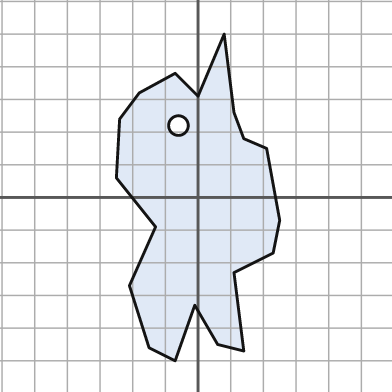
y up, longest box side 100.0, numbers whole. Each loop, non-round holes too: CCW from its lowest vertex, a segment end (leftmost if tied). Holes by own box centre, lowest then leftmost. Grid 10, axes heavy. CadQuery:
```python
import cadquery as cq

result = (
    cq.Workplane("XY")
    .moveTo(-7.0, -50.0)
    .lineTo(-1.0, -33.0)
    .lineTo(6.0, -45.0)
    .lineTo(14.0, -47.0)
    .lineTo(11.0, -23.0)
    .lineTo(23.0, -17.0)
    .lineTo(25.0, -7.0)
    .lineTo(21.0, 15.0)
    .lineTo(14.0, 18.0)
    .lineTo(11.0, 26.0)
    .lineTo(8.0, 50.0)
    .lineTo(0.0, 31.0)
    .lineTo(-7.0, 38.0)
    .lineTo(-18.0, 32.0)
    .lineTo(-24.0, 24.0)
    .lineTo(-25.0, 6.0)
    .lineTo(-13.0, -9.0)
    .lineTo(-21.0, -27.0)
    .lineTo(-15.0, -46.0)
    .close()
    .moveTo(-6.0, 22.0)
    .circle(3.0)
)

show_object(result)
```